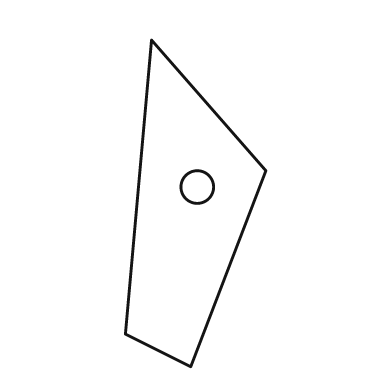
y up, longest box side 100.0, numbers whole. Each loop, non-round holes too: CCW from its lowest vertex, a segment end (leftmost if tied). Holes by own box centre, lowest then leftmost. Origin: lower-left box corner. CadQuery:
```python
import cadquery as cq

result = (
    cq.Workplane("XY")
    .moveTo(20.0, 0.0)
    .lineTo(43.0, 60.0)
    .lineTo(8.0, 100.0)
    .lineTo(0.0, 10.0)
    .close()
    .moveTo(22.0, 55.0)
    .circle(5.0)
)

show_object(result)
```